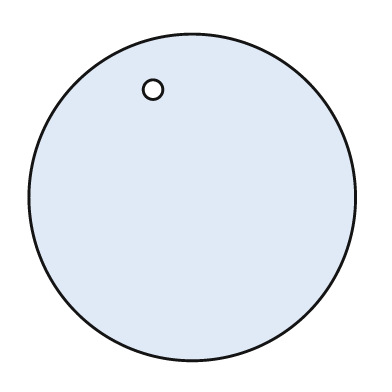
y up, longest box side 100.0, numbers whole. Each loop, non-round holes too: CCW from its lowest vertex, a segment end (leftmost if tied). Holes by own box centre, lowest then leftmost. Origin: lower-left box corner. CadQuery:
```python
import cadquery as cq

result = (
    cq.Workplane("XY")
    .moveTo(50.0, 50.0)
    .circle(50.0)
    .moveTo(38.0, 83.0)
    .circle(3.0)
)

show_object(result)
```